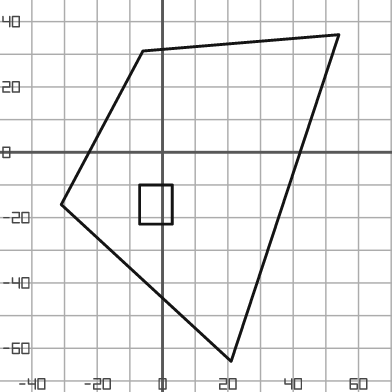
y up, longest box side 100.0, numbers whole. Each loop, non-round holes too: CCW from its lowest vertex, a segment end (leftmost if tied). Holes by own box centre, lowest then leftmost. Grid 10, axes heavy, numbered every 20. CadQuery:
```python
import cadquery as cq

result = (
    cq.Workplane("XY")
    .moveTo(21.0, -64.0)
    .lineTo(54.0, 36.0)
    .lineTo(-6.0, 31.0)
    .lineTo(-31.0, -16.0)
    .close()
    .moveTo(-7.0, -22.0)
    .lineTo(3.0, -22.0)
    .lineTo(3.0, -10.0)
    .lineTo(-7.0, -10.0)
    .close()
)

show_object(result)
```